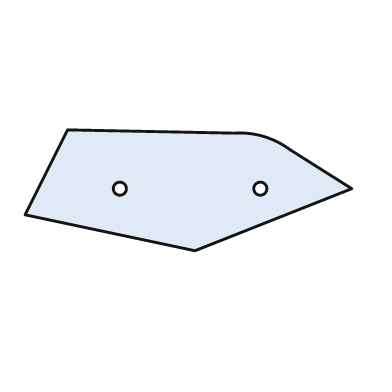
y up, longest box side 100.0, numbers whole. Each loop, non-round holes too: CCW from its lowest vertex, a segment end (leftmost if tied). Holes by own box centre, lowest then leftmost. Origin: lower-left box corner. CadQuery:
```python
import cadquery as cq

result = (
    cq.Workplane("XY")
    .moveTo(52.0, 0.0)
    .lineTo(100.0, 19.0)
    .lineTo(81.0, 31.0)
    .threePointArc((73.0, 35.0), (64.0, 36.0))
    .lineTo(13.0, 37.0)
    .lineTo(0.0, 11.0)
    .close()
    .moveTo(29.0, 19.0)
    .circle(2.0)
    .moveTo(72.0, 19.0)
    .circle(2.0)
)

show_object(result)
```